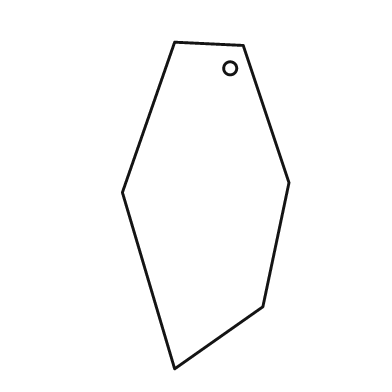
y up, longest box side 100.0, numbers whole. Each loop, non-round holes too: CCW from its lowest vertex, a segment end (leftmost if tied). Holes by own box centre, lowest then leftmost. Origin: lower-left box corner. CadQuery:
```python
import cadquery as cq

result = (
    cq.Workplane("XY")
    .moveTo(16.0, 0.0)
    .lineTo(43.0, 19.0)
    .lineTo(51.0, 57.0)
    .lineTo(37.0, 99.0)
    .lineTo(16.0, 100.0)
    .lineTo(0.0, 54.0)
    .close()
    .moveTo(33.0, 92.0)
    .circle(2.0)
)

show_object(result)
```